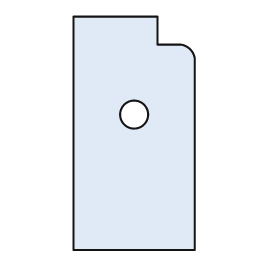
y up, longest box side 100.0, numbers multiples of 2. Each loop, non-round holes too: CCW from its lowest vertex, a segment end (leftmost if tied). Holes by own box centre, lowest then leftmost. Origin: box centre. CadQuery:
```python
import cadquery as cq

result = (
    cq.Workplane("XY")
    .moveTo(-26.0, -50.0)
    .lineTo(26.0, -50.0)
    .lineTo(26.0, 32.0)
    .threePointArc((24.0, 36.0), (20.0, 38.0))
    .lineTo(10.0, 38.0)
    .lineTo(10.0, 50.0)
    .lineTo(-26.0, 50.0)
    .close()
    .moveTo(0.0, 8.0)
    .circle(6.0)
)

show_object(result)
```